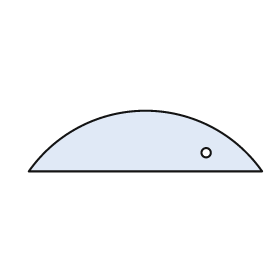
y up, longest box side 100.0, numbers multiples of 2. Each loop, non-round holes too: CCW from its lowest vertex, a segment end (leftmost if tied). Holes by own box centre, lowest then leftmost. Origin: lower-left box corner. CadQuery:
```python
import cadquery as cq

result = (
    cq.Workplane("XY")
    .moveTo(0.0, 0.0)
    .lineTo(100.0, 0.0)
    .threePointArc((50.0, 26.0), (0.0, 0.0))
    .close()
    .moveTo(76.0, 8.0)
    .circle(2.0)
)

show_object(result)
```